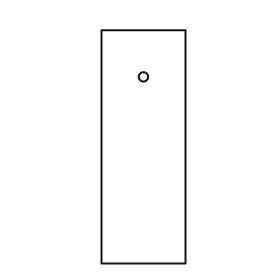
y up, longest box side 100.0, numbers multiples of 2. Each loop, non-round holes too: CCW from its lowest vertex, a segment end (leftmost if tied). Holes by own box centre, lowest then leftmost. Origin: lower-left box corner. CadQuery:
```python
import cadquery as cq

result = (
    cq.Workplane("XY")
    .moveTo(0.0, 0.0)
    .lineTo(36.0, 0.0)
    .lineTo(36.0, 100.0)
    .lineTo(0.0, 100.0)
    .close()
    .moveTo(18.0, 80.0)
    .circle(2.0)
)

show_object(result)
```